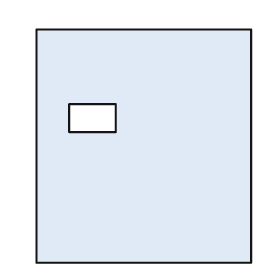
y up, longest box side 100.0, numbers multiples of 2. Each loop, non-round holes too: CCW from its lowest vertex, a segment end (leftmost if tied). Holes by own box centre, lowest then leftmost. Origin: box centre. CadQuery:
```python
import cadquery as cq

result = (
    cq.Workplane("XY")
    .moveTo(-46.0, -50.0)
    .lineTo(46.0, -50.0)
    .lineTo(46.0, 50.0)
    .lineTo(-46.0, 50.0)
    .close()
    .moveTo(-32.0, 6.0)
    .lineTo(-12.0, 6.0)
    .lineTo(-12.0, 18.0)
    .lineTo(-32.0, 18.0)
    .close()
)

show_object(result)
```